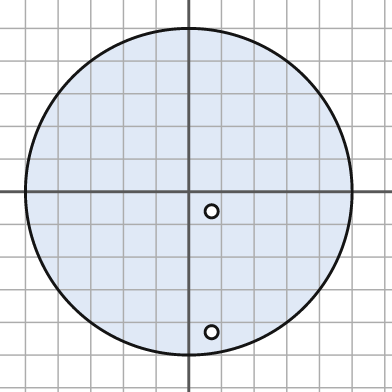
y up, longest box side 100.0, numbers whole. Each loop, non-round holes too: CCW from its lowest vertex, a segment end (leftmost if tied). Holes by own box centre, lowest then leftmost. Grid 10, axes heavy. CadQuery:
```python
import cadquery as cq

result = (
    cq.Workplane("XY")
    .moveTo(0.0, 0.0)
    .circle(50.0)
    .moveTo(7.0, -43.0)
    .circle(2.0)
    .moveTo(7.0, -6.0)
    .circle(2.0)
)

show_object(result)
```